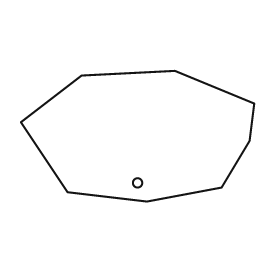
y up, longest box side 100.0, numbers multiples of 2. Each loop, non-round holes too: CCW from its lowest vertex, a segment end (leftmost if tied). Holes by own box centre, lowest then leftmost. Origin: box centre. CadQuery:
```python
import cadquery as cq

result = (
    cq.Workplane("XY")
    .moveTo(4.0, -28.0)
    .lineTo(36.0, -22.0)
    .lineTo(48.0, -2.0)
    .lineTo(50.0, 14.0)
    .lineTo(16.0, 28.0)
    .lineTo(-24.0, 26.0)
    .lineTo(-50.0, 6.0)
    .lineTo(-30.0, -24.0)
    .close()
    .moveTo(0.0, -20.0)
    .circle(2.0)
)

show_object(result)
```